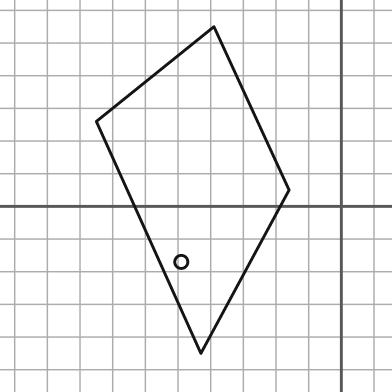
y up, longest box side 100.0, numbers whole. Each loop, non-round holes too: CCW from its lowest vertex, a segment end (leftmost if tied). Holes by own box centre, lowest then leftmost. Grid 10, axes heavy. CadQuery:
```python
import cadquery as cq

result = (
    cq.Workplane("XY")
    .moveTo(-43.0, -45.0)
    .lineTo(-16.0, 5.0)
    .lineTo(-39.0, 55.0)
    .lineTo(-75.0, 26.0)
    .close()
    .moveTo(-49.0, -17.0)
    .circle(2.0)
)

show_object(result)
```